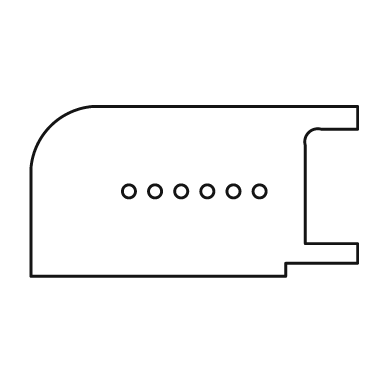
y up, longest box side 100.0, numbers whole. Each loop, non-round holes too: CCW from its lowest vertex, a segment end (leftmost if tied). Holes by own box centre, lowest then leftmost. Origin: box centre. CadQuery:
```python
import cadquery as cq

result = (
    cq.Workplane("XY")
    .moveTo(-50.0, -26.0)
    .lineTo(28.0, -26.0)
    .lineTo(28.0, -22.0)
    .lineTo(50.0, -22.0)
    .lineTo(50.0, -16.0)
    .lineTo(34.0, -16.0)
    .lineTo(34.0, 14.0)
    .threePointArc((35.0, 18.0), (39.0, 19.0))
    .lineTo(50.0, 19.0)
    .lineTo(50.0, 26.0)
    .lineTo(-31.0, 26.0)
    .threePointArc((-44.0, 20.0), (-50.0, 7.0))
    .close()
    .moveTo(-20.0, 0.0)
    .circle(2.0)
    .moveTo(-12.0, 0.0)
    .circle(2.0)
    .moveTo(-4.0, 0.0)
    .circle(2.0)
    .moveTo(4.0, 0.0)
    .circle(2.0)
    .moveTo(12.0, 0.0)
    .circle(2.0)
    .moveTo(20.0, 0.0)
    .circle(2.0)
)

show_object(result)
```